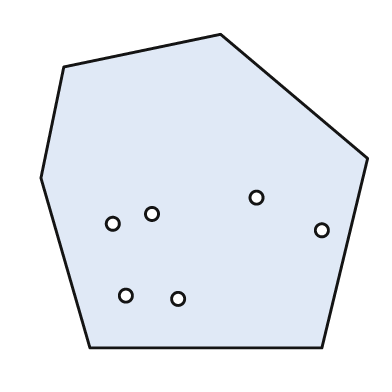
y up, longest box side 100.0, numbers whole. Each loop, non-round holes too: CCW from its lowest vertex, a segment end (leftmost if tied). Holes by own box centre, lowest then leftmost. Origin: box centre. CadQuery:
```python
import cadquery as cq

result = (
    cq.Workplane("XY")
    .moveTo(-35.0, -48.0)
    .lineTo(36.0, -48.0)
    .lineTo(50.0, 10.0)
    .lineTo(5.0, 48.0)
    .lineTo(-43.0, 38.0)
    .lineTo(-50.0, 4.0)
    .close()
    .moveTo(-8.0, -33.0)
    .circle(2.0)
    .moveTo(-24.0, -32.0)
    .circle(2.0)
    .moveTo(36.0, -12.0)
    .circle(2.0)
    .moveTo(-28.0, -10.0)
    .circle(2.0)
    .moveTo(-16.0, -7.0)
    .circle(2.0)
    .moveTo(16.0, -2.0)
    .circle(2.0)
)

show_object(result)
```